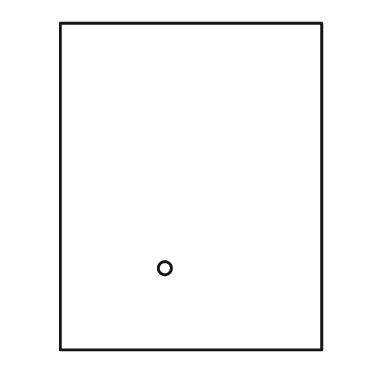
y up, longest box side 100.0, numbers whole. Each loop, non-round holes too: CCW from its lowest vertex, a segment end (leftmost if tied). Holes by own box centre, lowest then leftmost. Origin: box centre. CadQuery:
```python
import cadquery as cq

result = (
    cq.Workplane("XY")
    .moveTo(-40.0, -50.0)
    .lineTo(40.0, -50.0)
    .lineTo(40.0, 50.0)
    .lineTo(-40.0, 50.0)
    .close()
    .moveTo(-8.0, -25.0)
    .circle(2.0)
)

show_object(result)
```